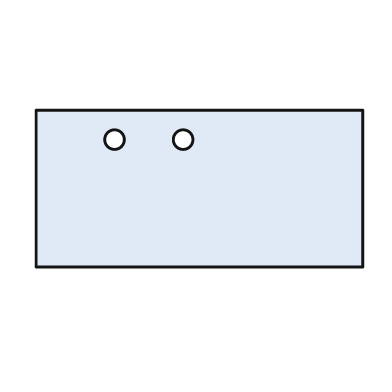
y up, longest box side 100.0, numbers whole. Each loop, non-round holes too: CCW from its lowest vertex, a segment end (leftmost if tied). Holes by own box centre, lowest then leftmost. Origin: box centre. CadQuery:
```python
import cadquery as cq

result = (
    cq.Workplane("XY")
    .moveTo(-50.0, -24.0)
    .lineTo(50.0, -24.0)
    .lineTo(50.0, 24.0)
    .lineTo(-50.0, 24.0)
    .close()
    .moveTo(-26.0, 15.0)
    .circle(3.0)
    .moveTo(-5.0, 15.0)
    .circle(3.0)
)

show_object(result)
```